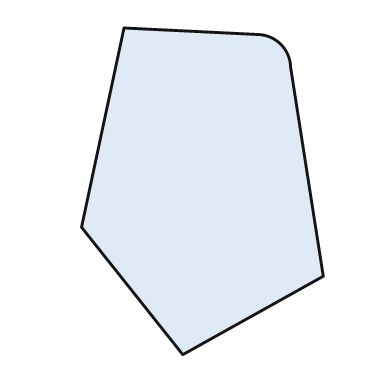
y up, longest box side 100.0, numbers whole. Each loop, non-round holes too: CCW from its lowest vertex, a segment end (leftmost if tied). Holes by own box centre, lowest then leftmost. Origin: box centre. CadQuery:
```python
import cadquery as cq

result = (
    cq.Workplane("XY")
    .moveTo(-6.0, -50.0)
    .lineTo(37.0, -26.0)
    .lineTo(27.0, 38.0)
    .threePointArc((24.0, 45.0), (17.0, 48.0))
    .lineTo(-24.0, 50.0)
    .lineTo(-37.0, -11.0)
    .close()
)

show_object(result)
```